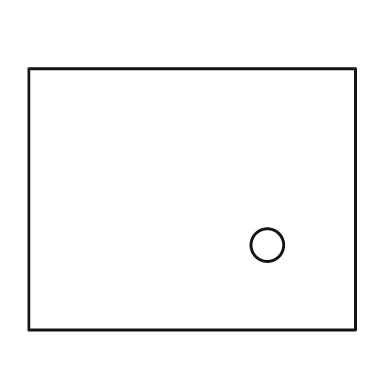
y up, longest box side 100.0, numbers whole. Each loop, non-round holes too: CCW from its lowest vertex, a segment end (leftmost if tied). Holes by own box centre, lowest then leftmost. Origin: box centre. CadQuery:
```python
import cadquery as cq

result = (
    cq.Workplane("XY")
    .moveTo(-50.0, -40.0)
    .lineTo(50.0, -40.0)
    .lineTo(50.0, 40.0)
    .lineTo(-50.0, 40.0)
    .close()
    .moveTo(23.0, -14.0)
    .circle(5.0)
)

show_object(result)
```